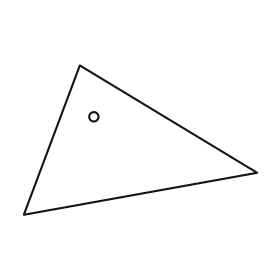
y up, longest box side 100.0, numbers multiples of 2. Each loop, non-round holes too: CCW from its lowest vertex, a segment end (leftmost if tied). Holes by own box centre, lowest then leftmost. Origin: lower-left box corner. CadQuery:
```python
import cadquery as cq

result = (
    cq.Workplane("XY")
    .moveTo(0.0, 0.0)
    .lineTo(100.0, 18.0)
    .lineTo(24.0, 64.0)
    .close()
    .moveTo(30.0, 42.0)
    .circle(2.0)
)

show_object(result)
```